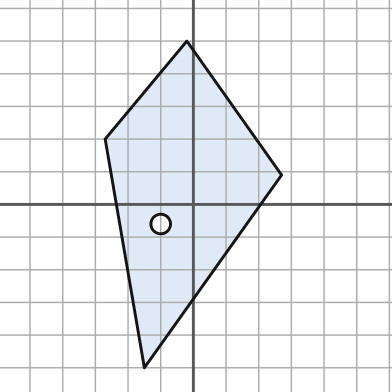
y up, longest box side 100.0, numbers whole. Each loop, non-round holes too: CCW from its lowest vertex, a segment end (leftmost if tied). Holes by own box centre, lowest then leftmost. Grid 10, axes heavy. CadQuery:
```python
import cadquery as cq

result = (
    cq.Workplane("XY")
    .moveTo(-15.0, -50.0)
    .lineTo(27.0, 9.0)
    .lineTo(-2.0, 50.0)
    .lineTo(-27.0, 20.0)
    .close()
    .moveTo(-10.0, -6.0)
    .circle(3.0)
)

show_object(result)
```